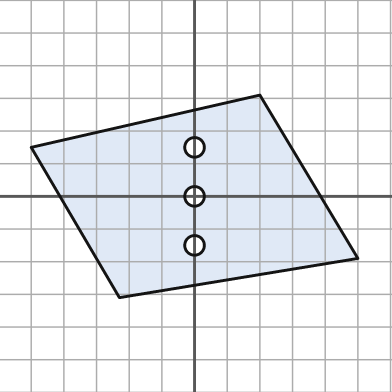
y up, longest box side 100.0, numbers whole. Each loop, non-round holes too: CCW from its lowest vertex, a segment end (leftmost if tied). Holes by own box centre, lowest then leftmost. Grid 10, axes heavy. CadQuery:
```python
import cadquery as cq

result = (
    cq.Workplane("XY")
    .moveTo(-23.0, -31.0)
    .lineTo(50.0, -19.0)
    .lineTo(20.0, 31.0)
    .lineTo(-50.0, 15.0)
    .close()
    .moveTo(0.0, -15.0)
    .circle(3.0)
    .moveTo(0.0, 0.0)
    .circle(3.0)
    .moveTo(0.0, 15.0)
    .circle(3.0)
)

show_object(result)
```